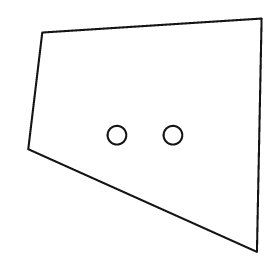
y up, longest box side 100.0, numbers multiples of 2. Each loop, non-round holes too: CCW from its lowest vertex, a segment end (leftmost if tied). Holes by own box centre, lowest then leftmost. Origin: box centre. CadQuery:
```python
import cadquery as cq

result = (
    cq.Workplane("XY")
    .moveTo(48.0, -50.0)
    .lineTo(50.0, 50.0)
    .lineTo(-44.0, 44.0)
    .lineTo(-50.0, -6.0)
    .close()
    .moveTo(-12.0, 0.0)
    .circle(4.0)
    .moveTo(12.0, 0.0)
    .circle(4.0)
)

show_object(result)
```